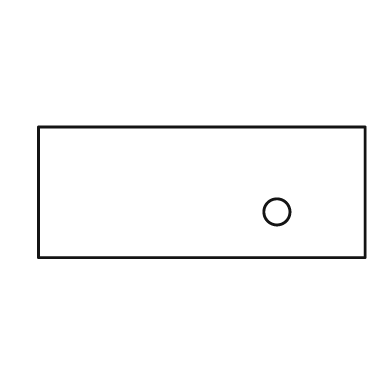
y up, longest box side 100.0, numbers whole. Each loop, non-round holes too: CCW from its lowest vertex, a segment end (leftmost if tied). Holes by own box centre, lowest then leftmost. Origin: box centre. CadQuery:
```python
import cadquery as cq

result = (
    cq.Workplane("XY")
    .moveTo(-50.0, -20.0)
    .lineTo(50.0, -20.0)
    .lineTo(50.0, 20.0)
    .lineTo(-50.0, 20.0)
    .close()
    .moveTo(23.0, -6.0)
    .circle(4.0)
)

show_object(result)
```